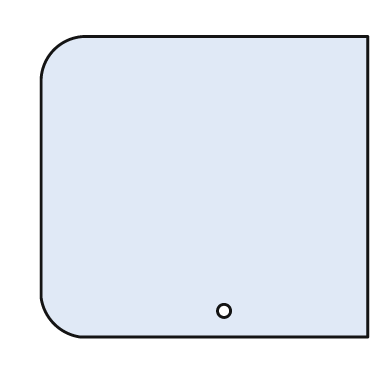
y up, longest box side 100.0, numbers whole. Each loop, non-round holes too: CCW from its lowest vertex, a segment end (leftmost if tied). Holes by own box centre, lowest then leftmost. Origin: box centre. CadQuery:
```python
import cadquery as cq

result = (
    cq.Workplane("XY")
    .moveTo(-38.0, -46.0)
    .lineTo(50.0, -46.0)
    .lineTo(50.0, 46.0)
    .lineTo(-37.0, 46.0)
    .threePointArc((-46.0, 42.0), (-50.0, 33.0))
    .lineTo(-50.0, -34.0)
    .threePointArc((-46.0, -42.0), (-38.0, -46.0))
    .close()
    .moveTo(6.0, -38.0)
    .circle(2.0)
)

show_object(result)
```